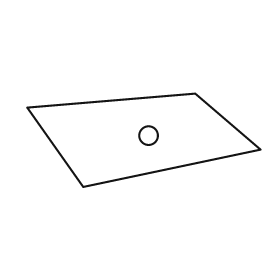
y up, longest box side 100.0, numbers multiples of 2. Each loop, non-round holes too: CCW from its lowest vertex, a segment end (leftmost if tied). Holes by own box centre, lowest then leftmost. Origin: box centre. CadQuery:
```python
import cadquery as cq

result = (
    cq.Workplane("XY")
    .moveTo(-26.0, -20.0)
    .lineTo(50.0, -4.0)
    .lineTo(22.0, 20.0)
    .lineTo(-50.0, 14.0)
    .close()
    .moveTo(2.0, 2.0)
    .circle(4.0)
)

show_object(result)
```